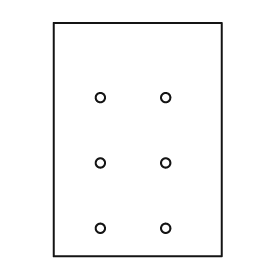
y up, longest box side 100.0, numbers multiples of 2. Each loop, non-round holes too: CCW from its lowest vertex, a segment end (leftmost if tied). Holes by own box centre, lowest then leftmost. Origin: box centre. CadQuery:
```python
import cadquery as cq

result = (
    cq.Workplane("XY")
    .moveTo(-36.0, -50.0)
    .lineTo(36.0, -50.0)
    .lineTo(36.0, 50.0)
    .lineTo(-36.0, 50.0)
    .close()
    .moveTo(-16.0, -38.0)
    .circle(2.0)
    .moveTo(12.0, -38.0)
    .circle(2.0)
    .moveTo(-16.0, -10.0)
    .circle(2.0)
    .moveTo(12.0, -10.0)
    .circle(2.0)
    .moveTo(-16.0, 18.0)
    .circle(2.0)
    .moveTo(12.0, 18.0)
    .circle(2.0)
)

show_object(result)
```